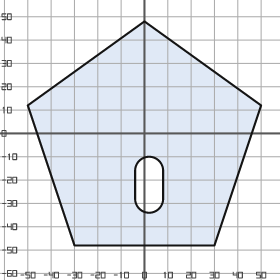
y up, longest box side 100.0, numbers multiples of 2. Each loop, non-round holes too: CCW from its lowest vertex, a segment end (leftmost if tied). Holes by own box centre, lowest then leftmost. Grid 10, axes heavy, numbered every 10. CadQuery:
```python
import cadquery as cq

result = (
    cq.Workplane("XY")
    .moveTo(-30.0, -48.0)
    .lineTo(30.0, -48.0)
    .lineTo(50.0, 12.0)
    .lineTo(0.0, 48.0)
    .lineTo(-50.0, 12.0)
    .close()
    .moveTo(-4.0, -28.0)
    .threePointArc((2.0, -34.0), (8.0, -28.0))
    .lineTo(8.0, -16.0)
    .threePointArc((2.0, -10.0), (-4.0, -16.0))
    .close()
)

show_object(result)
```